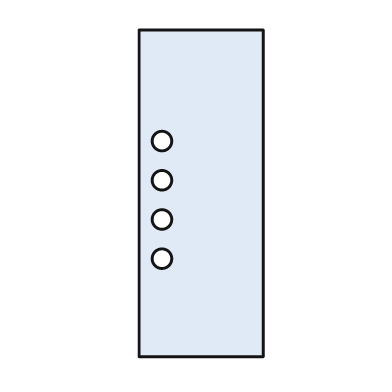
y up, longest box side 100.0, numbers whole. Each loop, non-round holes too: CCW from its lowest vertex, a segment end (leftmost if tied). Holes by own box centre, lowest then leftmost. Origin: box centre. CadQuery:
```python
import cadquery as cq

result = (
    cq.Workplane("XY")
    .moveTo(-19.0, -50.0)
    .lineTo(19.0, -50.0)
    .lineTo(19.0, 50.0)
    .lineTo(-19.0, 50.0)
    .close()
    .moveTo(-12.0, -20.0)
    .circle(3.0)
    .moveTo(-12.0, -8.0)
    .circle(3.0)
    .moveTo(-12.0, 4.0)
    .circle(3.0)
    .moveTo(-12.0, 16.0)
    .circle(3.0)
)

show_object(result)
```